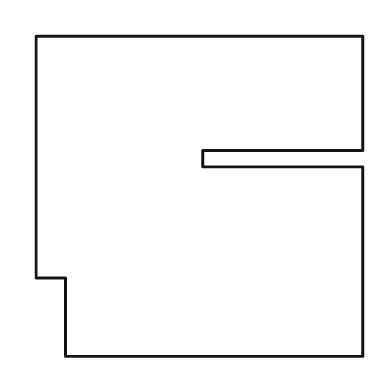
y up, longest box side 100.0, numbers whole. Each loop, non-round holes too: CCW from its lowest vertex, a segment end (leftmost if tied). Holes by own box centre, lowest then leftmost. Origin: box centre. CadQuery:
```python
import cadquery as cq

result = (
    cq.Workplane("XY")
    .moveTo(-41.0, -49.0)
    .lineTo(50.0, -49.0)
    .lineTo(50.0, 9.0)
    .lineTo(1.0, 9.0)
    .lineTo(1.0, 14.0)
    .lineTo(50.0, 14.0)
    .lineTo(50.0, 49.0)
    .lineTo(-50.0, 49.0)
    .lineTo(-50.0, -25.0)
    .lineTo(-41.0, -25.0)
    .close()
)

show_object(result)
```